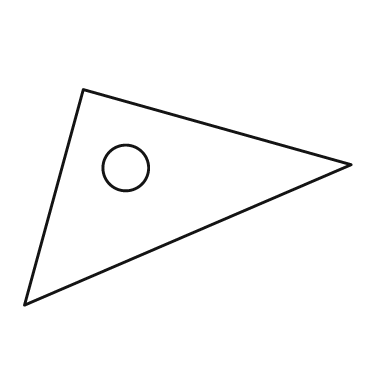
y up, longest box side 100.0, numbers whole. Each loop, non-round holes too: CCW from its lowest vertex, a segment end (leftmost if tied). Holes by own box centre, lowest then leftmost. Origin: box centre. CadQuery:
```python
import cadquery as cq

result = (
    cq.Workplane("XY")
    .moveTo(-50.0, -33.0)
    .lineTo(50.0, 10.0)
    .lineTo(-32.0, 33.0)
    .close()
    .moveTo(-19.0, 9.0)
    .circle(7.0)
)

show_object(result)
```